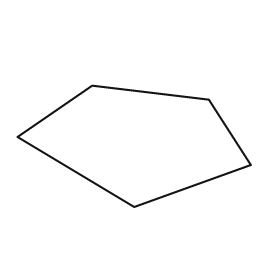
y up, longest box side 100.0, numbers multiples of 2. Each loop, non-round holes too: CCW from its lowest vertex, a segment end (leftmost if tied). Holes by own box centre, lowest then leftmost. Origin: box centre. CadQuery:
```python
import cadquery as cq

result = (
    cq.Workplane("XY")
    .moveTo(0.0, -26.0)
    .lineTo(50.0, -8.0)
    .lineTo(32.0, 20.0)
    .lineTo(-18.0, 26.0)
    .lineTo(-50.0, 4.0)
    .close()
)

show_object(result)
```